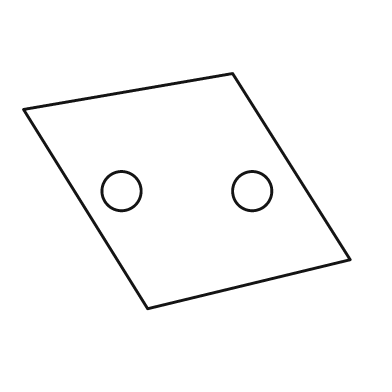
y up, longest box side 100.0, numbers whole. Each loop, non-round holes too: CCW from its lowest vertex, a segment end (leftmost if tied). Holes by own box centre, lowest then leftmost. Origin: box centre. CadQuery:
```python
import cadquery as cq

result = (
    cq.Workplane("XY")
    .moveTo(-12.0, -36.0)
    .lineTo(50.0, -21.0)
    .lineTo(14.0, 36.0)
    .lineTo(-50.0, 25.0)
    .close()
    .moveTo(-20.0, 0.0)
    .circle(6.0)
    .moveTo(20.0, 0.0)
    .circle(6.0)
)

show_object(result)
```